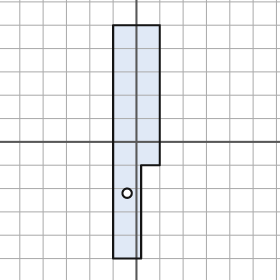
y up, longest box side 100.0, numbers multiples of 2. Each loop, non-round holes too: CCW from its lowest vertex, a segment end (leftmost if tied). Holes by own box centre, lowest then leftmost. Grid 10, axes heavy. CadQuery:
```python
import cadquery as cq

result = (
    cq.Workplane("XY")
    .moveTo(-10.0, -50.0)
    .lineTo(2.0, -50.0)
    .lineTo(2.0, -10.0)
    .lineTo(10.0, -10.0)
    .lineTo(10.0, 50.0)
    .lineTo(-10.0, 50.0)
    .close()
    .moveTo(-4.0, -22.0)
    .circle(2.0)
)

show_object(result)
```